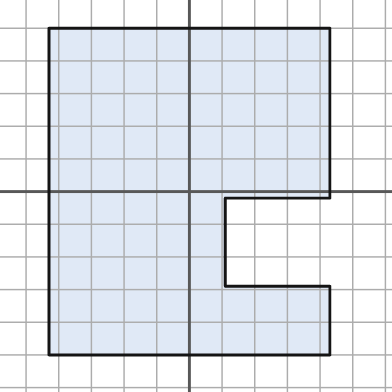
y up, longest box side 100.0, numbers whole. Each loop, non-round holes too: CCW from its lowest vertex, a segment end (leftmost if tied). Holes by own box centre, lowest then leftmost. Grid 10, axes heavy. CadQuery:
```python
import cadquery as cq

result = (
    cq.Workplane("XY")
    .moveTo(-43.0, -50.0)
    .lineTo(43.0, -50.0)
    .lineTo(43.0, -29.0)
    .lineTo(11.0, -29.0)
    .lineTo(11.0, -2.0)
    .lineTo(43.0, -2.0)
    .lineTo(43.0, 50.0)
    .lineTo(-43.0, 50.0)
    .close()
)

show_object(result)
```